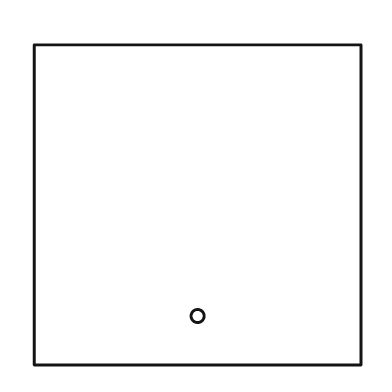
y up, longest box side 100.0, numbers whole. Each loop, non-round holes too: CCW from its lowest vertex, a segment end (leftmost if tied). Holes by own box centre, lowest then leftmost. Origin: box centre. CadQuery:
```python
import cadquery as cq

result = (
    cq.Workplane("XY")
    .moveTo(-50.0, -49.0)
    .lineTo(50.0, -49.0)
    .lineTo(50.0, 49.0)
    .lineTo(-50.0, 49.0)
    .close()
    .moveTo(0.0, -34.0)
    .circle(2.0)
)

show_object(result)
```